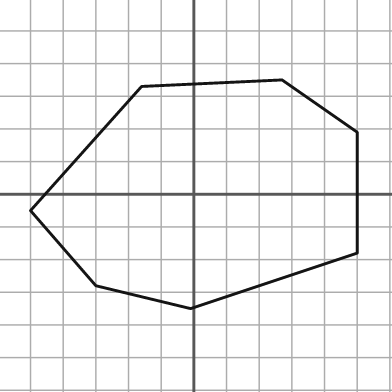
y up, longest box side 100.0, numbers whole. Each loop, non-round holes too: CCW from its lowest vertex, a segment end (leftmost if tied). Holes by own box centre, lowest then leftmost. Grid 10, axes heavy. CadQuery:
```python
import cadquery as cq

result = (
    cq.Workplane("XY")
    .moveTo(-1.0, -35.0)
    .lineTo(50.0, -18.0)
    .lineTo(50.0, 19.0)
    .lineTo(27.0, 35.0)
    .lineTo(-16.0, 33.0)
    .lineTo(-50.0, -5.0)
    .lineTo(-30.0, -28.0)
    .close()
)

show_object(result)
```